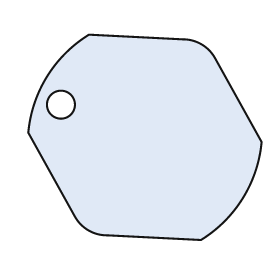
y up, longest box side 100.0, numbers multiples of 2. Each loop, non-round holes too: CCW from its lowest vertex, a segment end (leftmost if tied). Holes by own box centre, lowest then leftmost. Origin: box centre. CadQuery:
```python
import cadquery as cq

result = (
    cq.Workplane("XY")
    .moveTo(24.0, -44.0)
    .threePointArc((42.0, -26.0), (50.0, -2.0))
    .lineTo(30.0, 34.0)
    .threePointArc((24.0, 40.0), (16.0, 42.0))
    .lineTo(-24.0, 44.0)
    .threePointArc((-42.0, 26.0), (-50.0, 2.0))
    .lineTo(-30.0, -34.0)
    .threePointArc((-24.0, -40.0), (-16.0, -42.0))
    .close()
    .moveTo(-36.0, 14.0)
    .circle(6.0)
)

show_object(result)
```